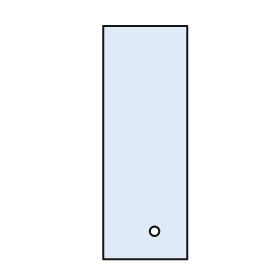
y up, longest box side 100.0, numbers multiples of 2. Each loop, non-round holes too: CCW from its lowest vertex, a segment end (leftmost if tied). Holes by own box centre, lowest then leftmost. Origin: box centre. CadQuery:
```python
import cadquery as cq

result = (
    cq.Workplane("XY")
    .moveTo(-18.0, -50.0)
    .lineTo(18.0, -50.0)
    .lineTo(18.0, 50.0)
    .lineTo(-18.0, 50.0)
    .close()
    .moveTo(4.0, -38.0)
    .circle(2.0)
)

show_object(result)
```